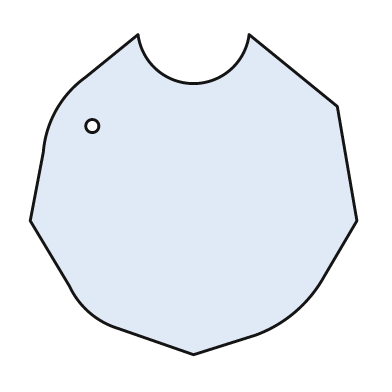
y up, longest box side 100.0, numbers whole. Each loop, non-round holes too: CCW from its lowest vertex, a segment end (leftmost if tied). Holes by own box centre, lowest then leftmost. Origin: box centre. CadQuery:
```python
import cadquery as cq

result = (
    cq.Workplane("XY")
    .moveTo(0.0, -49.0)
    .lineTo(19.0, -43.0)
    .threePointArc((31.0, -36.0), (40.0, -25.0))
    .lineTo(50.0, -8.0)
    .lineTo(44.0, 27.0)
    .lineTo(17.0, 49.0)
    .threePointArc((0.0, 34.0), (-17.0, 49.0))
    .lineTo(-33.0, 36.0)
    .threePointArc((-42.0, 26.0), (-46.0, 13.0))
    .lineTo(-50.0, -8.0)
    .lineTo(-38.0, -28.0)
    .threePointArc((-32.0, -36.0), (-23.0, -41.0))
    .close()
    .moveTo(-31.0, 21.0)
    .circle(2.0)
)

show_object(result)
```